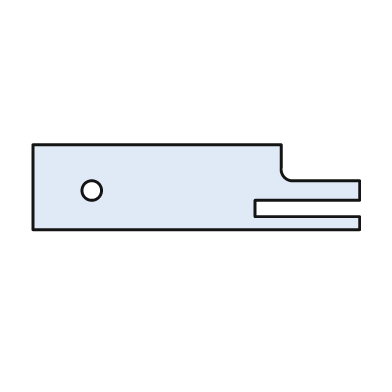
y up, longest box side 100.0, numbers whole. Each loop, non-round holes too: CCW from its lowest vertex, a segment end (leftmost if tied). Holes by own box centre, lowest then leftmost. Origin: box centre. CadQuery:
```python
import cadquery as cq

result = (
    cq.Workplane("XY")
    .moveTo(-50.0, -13.0)
    .lineTo(50.0, -13.0)
    .lineTo(50.0, -9.0)
    .lineTo(18.0, -9.0)
    .lineTo(18.0, -4.0)
    .lineTo(50.0, -4.0)
    .lineTo(50.0, 2.0)
    .lineTo(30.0, 2.0)
    .threePointArc((27.0, 3.0), (26.0, 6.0))
    .lineTo(26.0, 13.0)
    .lineTo(-50.0, 13.0)
    .close()
    .moveTo(-32.0, -1.0)
    .circle(3.0)
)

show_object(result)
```